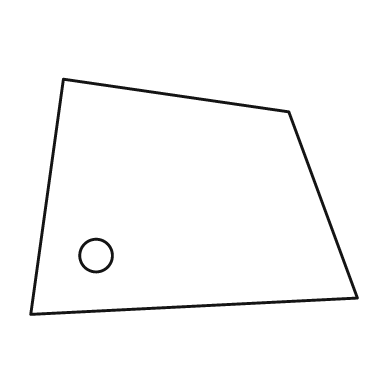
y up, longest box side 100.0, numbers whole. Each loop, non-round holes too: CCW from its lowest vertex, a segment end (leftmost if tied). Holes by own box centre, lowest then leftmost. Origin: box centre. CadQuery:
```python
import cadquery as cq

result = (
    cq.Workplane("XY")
    .moveTo(-50.0, -36.0)
    .lineTo(50.0, -31.0)
    .lineTo(29.0, 26.0)
    .lineTo(-40.0, 36.0)
    .close()
    .moveTo(-30.0, -18.0)
    .circle(5.0)
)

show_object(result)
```